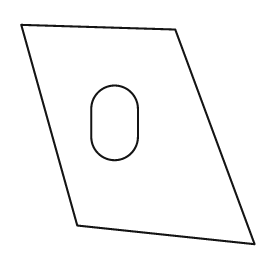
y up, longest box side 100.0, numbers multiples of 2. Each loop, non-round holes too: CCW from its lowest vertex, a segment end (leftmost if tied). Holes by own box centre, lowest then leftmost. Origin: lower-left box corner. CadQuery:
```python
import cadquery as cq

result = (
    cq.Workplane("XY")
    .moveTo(100.0, 0.0)
    .lineTo(66.0, 92.0)
    .lineTo(0.0, 94.0)
    .lineTo(24.0, 8.0)
    .close()
    .moveTo(30.0, 46.0)
    .threePointArc((40.0, 36.0), (50.0, 46.0))
    .lineTo(50.0, 58.0)
    .threePointArc((40.0, 68.0), (30.0, 58.0))
    .close()
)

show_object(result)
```